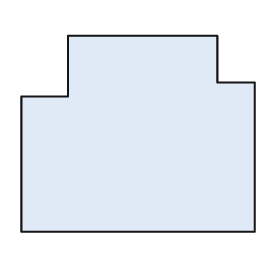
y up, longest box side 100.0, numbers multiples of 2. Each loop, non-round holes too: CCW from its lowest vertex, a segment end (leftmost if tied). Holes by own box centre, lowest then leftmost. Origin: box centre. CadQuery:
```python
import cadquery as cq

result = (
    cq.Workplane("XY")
    .moveTo(-50.0, -42.0)
    .lineTo(50.0, -42.0)
    .lineTo(50.0, 22.0)
    .lineTo(34.0, 22.0)
    .lineTo(34.0, 42.0)
    .lineTo(-30.0, 42.0)
    .lineTo(-30.0, 16.0)
    .lineTo(-50.0, 16.0)
    .close()
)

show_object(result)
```